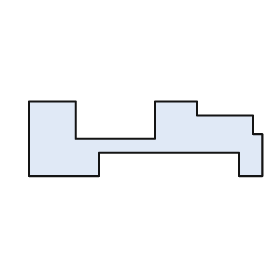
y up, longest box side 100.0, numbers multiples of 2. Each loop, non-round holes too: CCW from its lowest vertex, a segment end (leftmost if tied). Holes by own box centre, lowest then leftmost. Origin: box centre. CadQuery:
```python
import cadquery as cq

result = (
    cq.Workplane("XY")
    .moveTo(-50.0, -16.0)
    .lineTo(-20.0, -16.0)
    .lineTo(-20.0, -6.0)
    .lineTo(40.0, -6.0)
    .lineTo(40.0, -16.0)
    .lineTo(50.0, -16.0)
    .lineTo(50.0, 2.0)
    .lineTo(46.0, 2.0)
    .lineTo(46.0, 10.0)
    .lineTo(22.0, 10.0)
    .lineTo(22.0, 16.0)
    .lineTo(4.0, 16.0)
    .lineTo(4.0, 0.0)
    .lineTo(-30.0, 0.0)
    .lineTo(-30.0, 16.0)
    .lineTo(-50.0, 16.0)
    .close()
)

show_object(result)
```